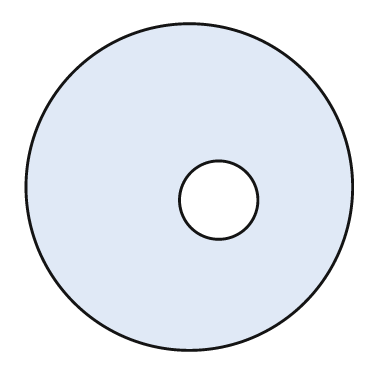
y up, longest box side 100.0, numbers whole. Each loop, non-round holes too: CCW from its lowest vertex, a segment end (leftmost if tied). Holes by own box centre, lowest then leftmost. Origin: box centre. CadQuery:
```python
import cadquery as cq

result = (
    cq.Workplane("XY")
    .moveTo(0.0, 0.0)
    .circle(50.0)
    .moveTo(9.0, -4.0)
    .circle(12.0)
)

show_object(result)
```